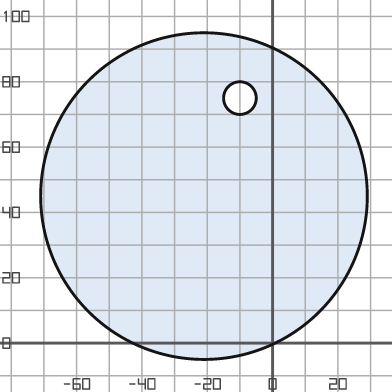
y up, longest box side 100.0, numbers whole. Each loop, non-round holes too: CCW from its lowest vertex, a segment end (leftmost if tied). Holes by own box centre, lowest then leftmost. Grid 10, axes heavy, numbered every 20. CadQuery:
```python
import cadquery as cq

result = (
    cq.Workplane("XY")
    .moveTo(-21.0, 45.0)
    .circle(50.0)
    .moveTo(-10.0, 75.0)
    .circle(5.0)
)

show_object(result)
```